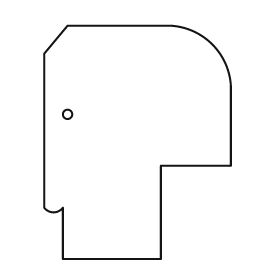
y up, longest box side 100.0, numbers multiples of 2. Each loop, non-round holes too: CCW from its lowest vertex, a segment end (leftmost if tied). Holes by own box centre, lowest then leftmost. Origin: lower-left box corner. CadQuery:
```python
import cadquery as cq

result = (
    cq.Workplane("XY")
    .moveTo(8.0, 0.0)
    .lineTo(50.0, 0.0)
    .lineTo(50.0, 40.0)
    .lineTo(80.0, 40.0)
    .lineTo(80.0, 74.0)
    .threePointArc((72.0, 92.0), (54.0, 100.0))
    .lineTo(10.0, 100.0)
    .lineTo(0.0, 88.0)
    .lineTo(0.0, 22.0)
    .threePointArc((4.0, 20.0), (8.0, 22.0))
    .close()
    .moveTo(10.0, 62.0)
    .circle(2.0)
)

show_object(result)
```